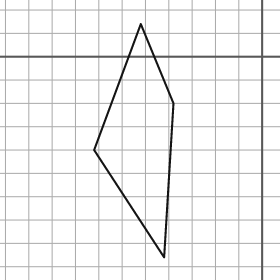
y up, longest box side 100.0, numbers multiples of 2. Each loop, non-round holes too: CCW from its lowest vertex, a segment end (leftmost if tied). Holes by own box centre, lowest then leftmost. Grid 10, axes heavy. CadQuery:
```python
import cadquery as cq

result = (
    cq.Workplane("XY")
    .moveTo(-42.0, -86.0)
    .lineTo(-38.0, -20.0)
    .lineTo(-52.0, 14.0)
    .lineTo(-72.0, -40.0)
    .close()
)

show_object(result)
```